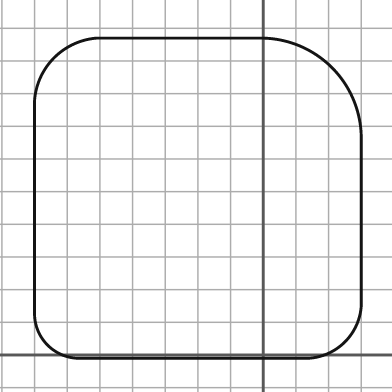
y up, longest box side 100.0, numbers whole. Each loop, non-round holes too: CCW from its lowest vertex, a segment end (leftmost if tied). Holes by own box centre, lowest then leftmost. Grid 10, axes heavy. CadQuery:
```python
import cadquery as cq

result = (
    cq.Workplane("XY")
    .moveTo(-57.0, -1.0)
    .lineTo(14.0, -1.0)
    .threePointArc((25.0, 4.0), (30.0, 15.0))
    .lineTo(30.0, 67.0)
    .threePointArc((21.0, 88.0), (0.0, 97.0))
    .lineTo(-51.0, 97.0)
    .threePointArc((-64.0, 91.0), (-70.0, 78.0))
    .lineTo(-70.0, 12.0)
    .threePointArc((-66.0, 3.0), (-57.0, -1.0))
    .close()
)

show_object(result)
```